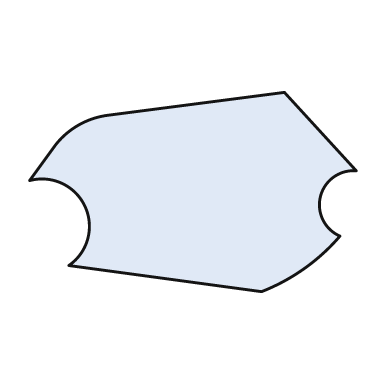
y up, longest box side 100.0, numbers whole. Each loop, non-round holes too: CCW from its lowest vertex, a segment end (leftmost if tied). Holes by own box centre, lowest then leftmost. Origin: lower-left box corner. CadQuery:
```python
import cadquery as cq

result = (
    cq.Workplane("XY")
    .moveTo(71.0, 0.0)
    .threePointArc((84.0, 7.0), (95.0, 17.0))
    .threePointArc((89.0, 29.0), (100.0, 37.0))
    .lineTo(78.0, 61.0)
    .lineTo(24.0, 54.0)
    .threePointArc((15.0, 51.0), (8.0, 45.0))
    .lineTo(0.0, 34.0)
    .threePointArc((17.0, 26.0), (12.0, 8.0))
    .close()
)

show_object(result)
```